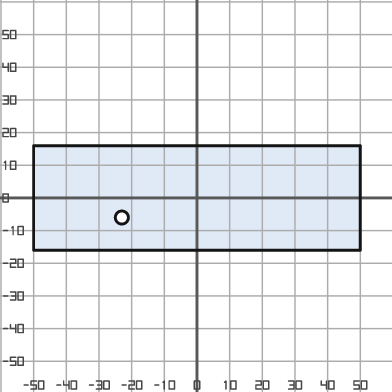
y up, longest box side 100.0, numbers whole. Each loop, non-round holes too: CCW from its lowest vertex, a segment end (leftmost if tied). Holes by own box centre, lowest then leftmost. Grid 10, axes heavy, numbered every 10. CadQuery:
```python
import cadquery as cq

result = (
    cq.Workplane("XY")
    .moveTo(-50.0, -16.0)
    .lineTo(50.0, -16.0)
    .lineTo(50.0, 16.0)
    .lineTo(-50.0, 16.0)
    .close()
    .moveTo(-23.0, -6.0)
    .circle(2.0)
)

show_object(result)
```